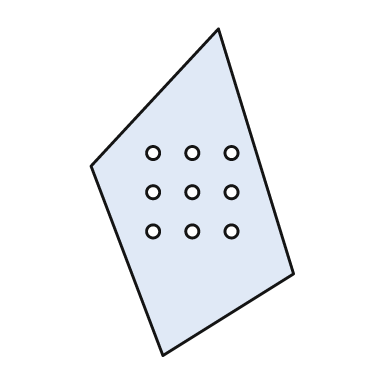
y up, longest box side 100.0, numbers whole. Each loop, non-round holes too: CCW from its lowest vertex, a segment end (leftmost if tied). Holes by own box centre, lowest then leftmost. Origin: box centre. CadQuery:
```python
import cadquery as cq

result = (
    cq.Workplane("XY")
    .moveTo(-9.0, -50.0)
    .lineTo(31.0, -25.0)
    .lineTo(8.0, 50.0)
    .lineTo(-31.0, 8.0)
    .close()
    .moveTo(-12.0, -12.0)
    .circle(2.0)
    .moveTo(0.0, -12.0)
    .circle(2.0)
    .moveTo(12.0, -12.0)
    .circle(2.0)
    .moveTo(-12.0, 0.0)
    .circle(2.0)
    .moveTo(0.0, 0.0)
    .circle(2.0)
    .moveTo(12.0, 0.0)
    .circle(2.0)
    .moveTo(-12.0, 12.0)
    .circle(2.0)
    .moveTo(0.0, 12.0)
    .circle(2.0)
    .moveTo(12.0, 12.0)
    .circle(2.0)
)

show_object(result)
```